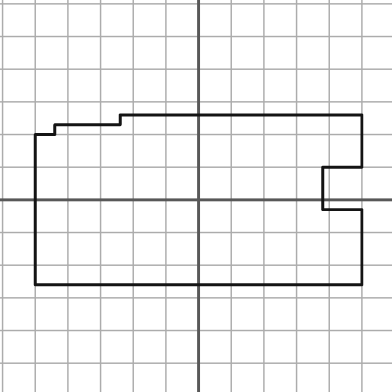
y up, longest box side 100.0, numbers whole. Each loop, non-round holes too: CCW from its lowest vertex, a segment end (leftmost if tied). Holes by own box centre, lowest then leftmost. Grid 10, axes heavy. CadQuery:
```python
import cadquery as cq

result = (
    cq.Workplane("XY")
    .moveTo(-50.0, -26.0)
    .lineTo(50.0, -26.0)
    .lineTo(50.0, -3.0)
    .lineTo(38.0, -3.0)
    .lineTo(38.0, 10.0)
    .lineTo(50.0, 10.0)
    .lineTo(50.0, 26.0)
    .lineTo(-24.0, 26.0)
    .lineTo(-24.0, 23.0)
    .lineTo(-44.0, 23.0)
    .lineTo(-44.0, 20.0)
    .lineTo(-50.0, 20.0)
    .close()
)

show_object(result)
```